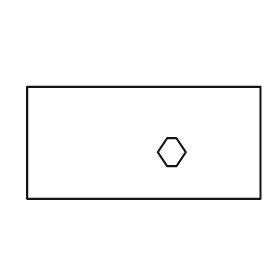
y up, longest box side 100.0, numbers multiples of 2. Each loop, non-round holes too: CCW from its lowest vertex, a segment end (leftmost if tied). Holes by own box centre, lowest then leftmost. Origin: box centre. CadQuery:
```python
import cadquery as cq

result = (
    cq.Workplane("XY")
    .moveTo(-50.0, -24.0)
    .lineTo(50.0, -24.0)
    .lineTo(50.0, 24.0)
    .lineTo(-50.0, 24.0)
    .close()
    .moveTo(10.0, -10.0)
    .lineTo(14.0, -10.0)
    .lineTo(18.0, -4.0)
    .lineTo(14.0, 2.0)
    .lineTo(10.0, 2.0)
    .lineTo(6.0, -4.0)
    .close()
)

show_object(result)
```